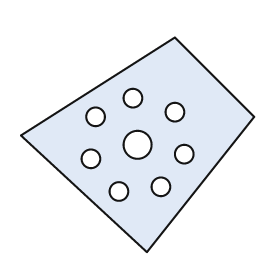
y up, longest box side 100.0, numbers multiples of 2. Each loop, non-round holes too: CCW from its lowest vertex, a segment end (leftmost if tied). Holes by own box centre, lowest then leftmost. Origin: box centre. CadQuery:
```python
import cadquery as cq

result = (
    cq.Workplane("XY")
    .moveTo(4.0, -46.0)
    .lineTo(50.0, 12.0)
    .lineTo(16.0, 46.0)
    .lineTo(-50.0, 4.0)
    .close()
    .moveTo(-8.0, -20.0)
    .circle(4.0)
    .moveTo(10.0, -18.0)
    .circle(4.0)
    .moveTo(-20.0, -6.0)
    .circle(4.0)
    .moveTo(20.0, -4.0)
    .circle(4.0)
    .moveTo(0.0, 0.0)
    .circle(6.0)
    .moveTo(-18.0, 12.0)
    .circle(4.0)
    .moveTo(16.0, 14.0)
    .circle(4.0)
    .moveTo(-2.0, 20.0)
    .circle(4.0)
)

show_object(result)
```